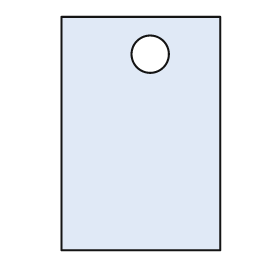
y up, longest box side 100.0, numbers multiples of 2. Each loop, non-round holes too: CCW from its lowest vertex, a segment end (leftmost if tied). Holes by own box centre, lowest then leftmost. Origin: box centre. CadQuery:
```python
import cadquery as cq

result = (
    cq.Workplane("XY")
    .moveTo(-34.0, -50.0)
    .lineTo(34.0, -50.0)
    .lineTo(34.0, 50.0)
    .lineTo(-34.0, 50.0)
    .close()
    .moveTo(4.0, 34.0)
    .circle(8.0)
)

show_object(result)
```